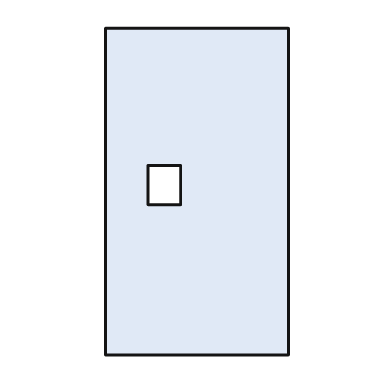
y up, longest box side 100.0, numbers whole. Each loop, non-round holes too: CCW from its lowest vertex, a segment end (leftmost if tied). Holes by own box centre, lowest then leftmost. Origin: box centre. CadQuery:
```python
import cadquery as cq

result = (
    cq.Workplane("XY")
    .moveTo(-28.0, -50.0)
    .lineTo(28.0, -50.0)
    .lineTo(28.0, 50.0)
    .lineTo(-28.0, 50.0)
    .close()
    .moveTo(-15.0, -4.0)
    .lineTo(-5.0, -4.0)
    .lineTo(-5.0, 8.0)
    .lineTo(-15.0, 8.0)
    .close()
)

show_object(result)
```